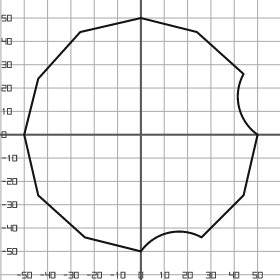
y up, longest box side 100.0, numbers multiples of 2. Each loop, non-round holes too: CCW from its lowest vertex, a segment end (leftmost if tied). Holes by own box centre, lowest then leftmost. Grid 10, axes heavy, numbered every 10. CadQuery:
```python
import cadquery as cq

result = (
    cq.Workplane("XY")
    .moveTo(0.0, -50.0)
    .threePointArc((12.0, -42.0), (26.0, -44.0))
    .lineTo(44.0, -26.0)
    .lineTo(50.0, 0.0)
    .threePointArc((42.0, 12.0), (44.0, 26.0))
    .lineTo(24.0, 44.0)
    .lineTo(0.0, 50.0)
    .lineTo(-26.0, 44.0)
    .lineTo(-44.0, 24.0)
    .lineTo(-50.0, 0.0)
    .lineTo(-44.0, -26.0)
    .lineTo(-24.0, -44.0)
    .close()
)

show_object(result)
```